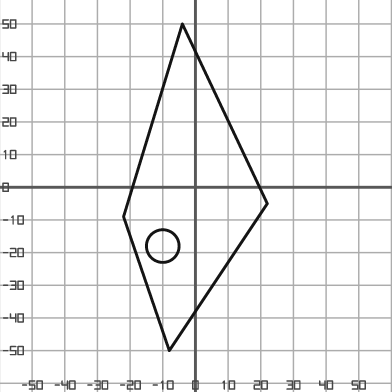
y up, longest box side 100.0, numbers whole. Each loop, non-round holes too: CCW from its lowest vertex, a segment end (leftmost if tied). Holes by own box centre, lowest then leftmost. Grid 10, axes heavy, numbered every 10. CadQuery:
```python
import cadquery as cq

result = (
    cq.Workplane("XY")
    .moveTo(-8.0, -50.0)
    .lineTo(22.0, -5.0)
    .lineTo(-4.0, 50.0)
    .lineTo(-22.0, -9.0)
    .close()
    .moveTo(-10.0, -18.0)
    .circle(5.0)
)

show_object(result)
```